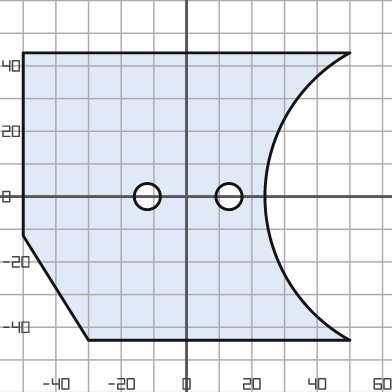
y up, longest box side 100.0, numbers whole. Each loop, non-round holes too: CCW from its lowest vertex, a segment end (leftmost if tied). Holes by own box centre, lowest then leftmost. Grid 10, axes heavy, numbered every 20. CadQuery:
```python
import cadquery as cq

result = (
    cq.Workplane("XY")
    .moveTo(-30.0, -44.0)
    .lineTo(50.0, -44.0)
    .threePointArc((24.0, 0.0), (50.0, 44.0))
    .lineTo(-50.0, 44.0)
    .lineTo(-50.0, -12.0)
    .close()
    .moveTo(-12.0, 0.0)
    .circle(4.0)
    .moveTo(13.0, 0.0)
    .circle(4.0)
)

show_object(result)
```